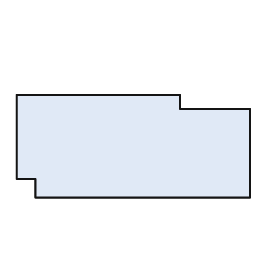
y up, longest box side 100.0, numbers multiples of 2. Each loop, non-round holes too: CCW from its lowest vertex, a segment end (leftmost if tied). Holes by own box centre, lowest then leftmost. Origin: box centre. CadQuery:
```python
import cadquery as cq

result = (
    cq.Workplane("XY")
    .moveTo(-42.0, -22.0)
    .lineTo(50.0, -22.0)
    .lineTo(50.0, 16.0)
    .lineTo(20.0, 16.0)
    .lineTo(20.0, 22.0)
    .lineTo(-50.0, 22.0)
    .lineTo(-50.0, -14.0)
    .lineTo(-42.0, -14.0)
    .close()
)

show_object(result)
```